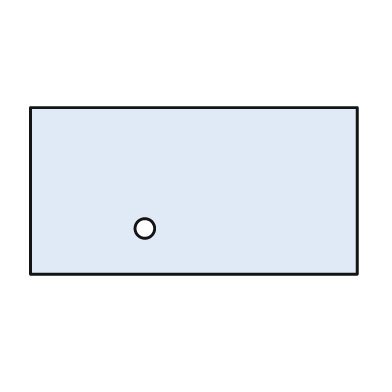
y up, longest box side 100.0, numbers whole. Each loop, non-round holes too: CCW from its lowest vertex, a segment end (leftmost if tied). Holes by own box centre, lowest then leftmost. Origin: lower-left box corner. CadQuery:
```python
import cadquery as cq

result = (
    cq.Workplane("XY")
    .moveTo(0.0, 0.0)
    .lineTo(100.0, 0.0)
    .lineTo(100.0, 51.0)
    .lineTo(0.0, 51.0)
    .close()
    .moveTo(35.0, 14.0)
    .circle(3.0)
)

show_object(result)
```